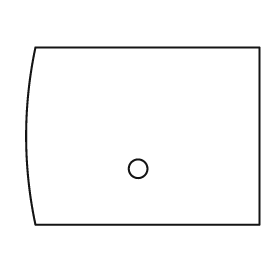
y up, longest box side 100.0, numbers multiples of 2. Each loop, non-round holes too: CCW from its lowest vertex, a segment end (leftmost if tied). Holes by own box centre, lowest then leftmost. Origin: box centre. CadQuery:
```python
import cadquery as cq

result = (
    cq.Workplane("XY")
    .moveTo(-46.0, -38.0)
    .lineTo(50.0, -38.0)
    .lineTo(50.0, 38.0)
    .lineTo(-46.0, 38.0)
    .threePointArc((-50.0, 0.0), (-46.0, -38.0))
    .close()
    .moveTo(-2.0, -14.0)
    .circle(4.0)
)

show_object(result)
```